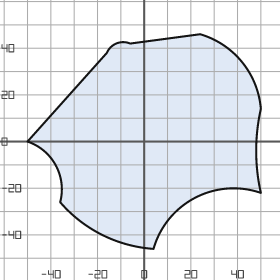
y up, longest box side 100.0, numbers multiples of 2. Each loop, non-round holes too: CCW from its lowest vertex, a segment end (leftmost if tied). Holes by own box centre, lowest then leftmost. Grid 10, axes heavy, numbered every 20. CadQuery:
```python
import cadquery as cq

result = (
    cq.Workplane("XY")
    .moveTo(4.0, -46.0)
    .threePointArc((22.0, -24.0), (50.0, -22.0))
    .threePointArc((48.0, -4.0), (50.0, 14.0))
    .threePointArc((42.0, 34.0), (24.0, 46.0))
    .lineTo(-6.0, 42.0)
    .threePointArc((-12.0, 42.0), (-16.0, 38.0))
    .lineTo(-50.0, 0.0)
    .threePointArc((-38.0, -10.0), (-36.0, -26.0))
    .threePointArc((-18.0, -40.0), (4.0, -46.0))
    .close()
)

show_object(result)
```